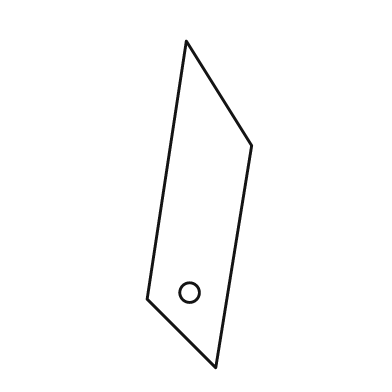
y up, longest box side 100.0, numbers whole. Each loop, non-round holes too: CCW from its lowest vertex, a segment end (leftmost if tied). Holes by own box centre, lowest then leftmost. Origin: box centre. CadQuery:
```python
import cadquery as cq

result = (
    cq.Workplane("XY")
    .moveTo(5.0, -50.0)
    .lineTo(16.0, 18.0)
    .lineTo(-4.0, 50.0)
    .lineTo(-16.0, -29.0)
    .close()
    .moveTo(-3.0, -27.0)
    .circle(3.0)
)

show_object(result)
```